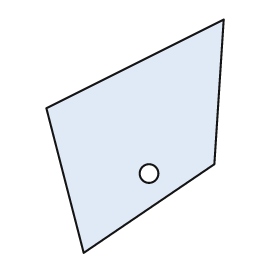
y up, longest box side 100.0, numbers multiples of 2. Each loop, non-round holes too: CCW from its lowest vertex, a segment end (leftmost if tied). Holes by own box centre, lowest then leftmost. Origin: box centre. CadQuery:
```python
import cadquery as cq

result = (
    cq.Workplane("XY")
    .moveTo(-22.0, -50.0)
    .lineTo(34.0, -12.0)
    .lineTo(38.0, 50.0)
    .lineTo(-38.0, 12.0)
    .close()
    .moveTo(6.0, -16.0)
    .circle(4.0)
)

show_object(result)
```